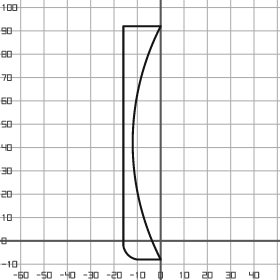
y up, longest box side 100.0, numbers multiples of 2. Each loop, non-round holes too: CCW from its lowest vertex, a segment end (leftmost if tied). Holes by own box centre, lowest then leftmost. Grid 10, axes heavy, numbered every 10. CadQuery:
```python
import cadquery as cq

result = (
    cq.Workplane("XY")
    .moveTo(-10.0, -8.0)
    .lineTo(0.0, -8.0)
    .threePointArc((-12.0, 42.0), (0.0, 92.0))
    .lineTo(-16.0, 92.0)
    .lineTo(-16.0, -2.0)
    .threePointArc((-14.0, -6.0), (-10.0, -8.0))
    .close()
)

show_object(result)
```